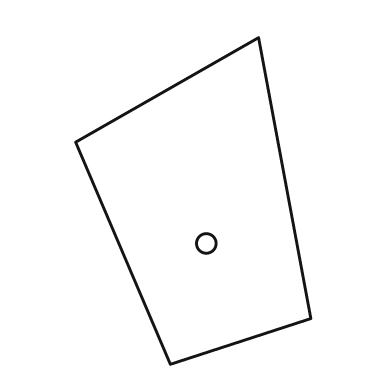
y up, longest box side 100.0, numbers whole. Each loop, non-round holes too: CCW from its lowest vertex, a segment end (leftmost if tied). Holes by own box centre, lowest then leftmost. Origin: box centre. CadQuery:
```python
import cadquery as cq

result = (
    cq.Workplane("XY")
    .moveTo(-7.0, -50.0)
    .lineTo(36.0, -36.0)
    .lineTo(20.0, 50.0)
    .lineTo(-36.0, 18.0)
    .close()
    .moveTo(4.0, -13.0)
    .circle(3.0)
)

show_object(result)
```